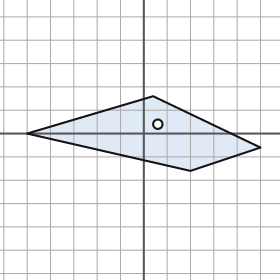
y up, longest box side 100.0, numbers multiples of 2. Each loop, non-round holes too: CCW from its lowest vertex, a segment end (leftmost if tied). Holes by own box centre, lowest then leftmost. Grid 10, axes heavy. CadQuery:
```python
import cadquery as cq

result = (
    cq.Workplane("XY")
    .moveTo(20.0, -16.0)
    .lineTo(50.0, -6.0)
    .lineTo(4.0, 16.0)
    .lineTo(-50.0, 0.0)
    .close()
    .moveTo(6.0, 4.0)
    .circle(2.0)
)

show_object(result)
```